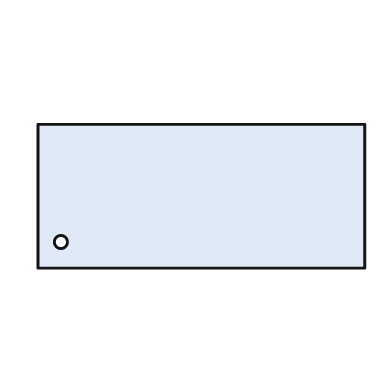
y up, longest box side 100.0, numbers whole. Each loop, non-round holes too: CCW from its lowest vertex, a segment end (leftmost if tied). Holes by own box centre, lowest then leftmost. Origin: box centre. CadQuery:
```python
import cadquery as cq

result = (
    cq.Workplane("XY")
    .moveTo(-50.0, -22.0)
    .lineTo(50.0, -22.0)
    .lineTo(50.0, 22.0)
    .lineTo(-50.0, 22.0)
    .close()
    .moveTo(-43.0, -14.0)
    .circle(2.0)
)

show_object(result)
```